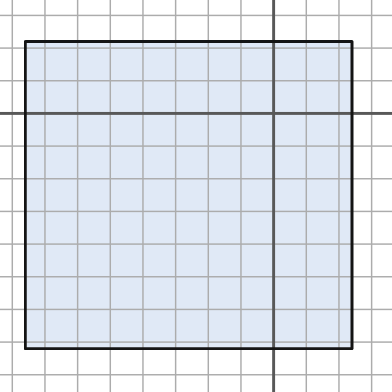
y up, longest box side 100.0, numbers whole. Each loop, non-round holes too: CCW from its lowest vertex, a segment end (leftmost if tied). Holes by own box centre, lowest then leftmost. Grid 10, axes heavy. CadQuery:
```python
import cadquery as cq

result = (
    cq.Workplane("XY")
    .moveTo(-76.0, -72.0)
    .lineTo(24.0, -72.0)
    .lineTo(24.0, 22.0)
    .lineTo(-76.0, 22.0)
    .close()
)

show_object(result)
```